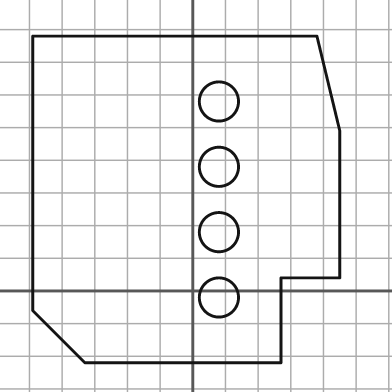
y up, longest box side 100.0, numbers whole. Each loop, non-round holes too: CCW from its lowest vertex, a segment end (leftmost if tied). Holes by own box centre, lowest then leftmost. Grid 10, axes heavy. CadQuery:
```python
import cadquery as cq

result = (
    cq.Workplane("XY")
    .moveTo(-33.0, -22.0)
    .lineTo(27.0, -22.0)
    .lineTo(27.0, 4.0)
    .lineTo(45.0, 4.0)
    .lineTo(45.0, 49.0)
    .lineTo(38.0, 78.0)
    .lineTo(-49.0, 78.0)
    .lineTo(-49.0, -6.0)
    .close()
    .moveTo(8.0, -2.0)
    .circle(6.0)
    .moveTo(8.0, 18.0)
    .circle(6.0)
    .moveTo(8.0, 38.0)
    .circle(6.0)
    .moveTo(8.0, 58.0)
    .circle(6.0)
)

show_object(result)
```